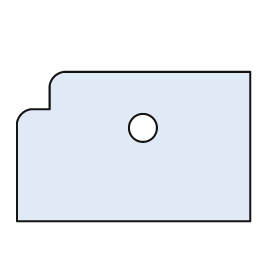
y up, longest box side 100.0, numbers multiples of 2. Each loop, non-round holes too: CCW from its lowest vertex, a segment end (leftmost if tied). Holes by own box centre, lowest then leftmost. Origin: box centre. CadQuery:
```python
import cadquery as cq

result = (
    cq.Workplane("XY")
    .moveTo(-50.0, -32.0)
    .lineTo(50.0, -32.0)
    .lineTo(50.0, 32.0)
    .lineTo(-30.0, 32.0)
    .threePointArc((-34.0, 30.0), (-36.0, 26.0))
    .lineTo(-36.0, 16.0)
    .lineTo(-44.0, 16.0)
    .threePointArc((-48.0, 14.0), (-50.0, 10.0))
    .close()
    .moveTo(4.0, 8.0)
    .circle(6.0)
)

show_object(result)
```